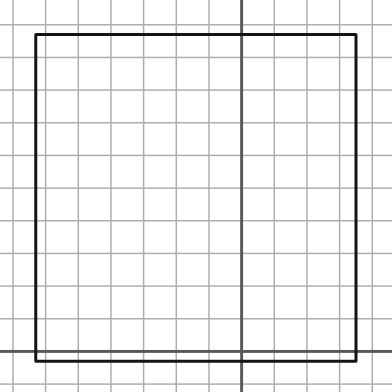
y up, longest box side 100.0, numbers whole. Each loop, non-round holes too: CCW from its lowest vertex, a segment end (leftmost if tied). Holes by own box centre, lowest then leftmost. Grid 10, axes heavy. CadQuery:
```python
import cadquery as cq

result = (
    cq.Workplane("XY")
    .moveTo(-63.0, -3.0)
    .lineTo(35.0, -3.0)
    .lineTo(35.0, 97.0)
    .lineTo(-63.0, 97.0)
    .close()
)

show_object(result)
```